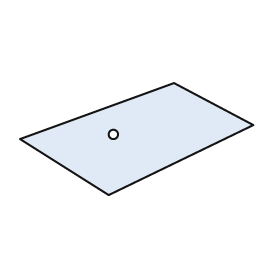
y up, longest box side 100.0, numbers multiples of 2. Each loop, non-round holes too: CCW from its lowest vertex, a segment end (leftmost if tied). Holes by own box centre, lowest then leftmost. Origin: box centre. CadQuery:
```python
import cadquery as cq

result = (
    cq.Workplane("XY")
    .moveTo(-12.0, -24.0)
    .lineTo(50.0, 6.0)
    .lineTo(16.0, 24.0)
    .lineTo(-50.0, 0.0)
    .close()
    .moveTo(-10.0, 2.0)
    .circle(2.0)
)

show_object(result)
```